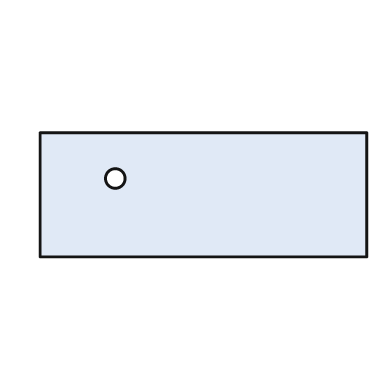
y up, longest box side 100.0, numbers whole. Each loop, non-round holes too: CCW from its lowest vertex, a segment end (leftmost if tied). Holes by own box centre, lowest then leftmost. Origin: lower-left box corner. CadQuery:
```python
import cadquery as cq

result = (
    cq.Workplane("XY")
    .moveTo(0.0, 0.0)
    .lineTo(100.0, 0.0)
    .lineTo(100.0, 38.0)
    .lineTo(0.0, 38.0)
    .close()
    .moveTo(23.0, 24.0)
    .circle(3.0)
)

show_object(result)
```